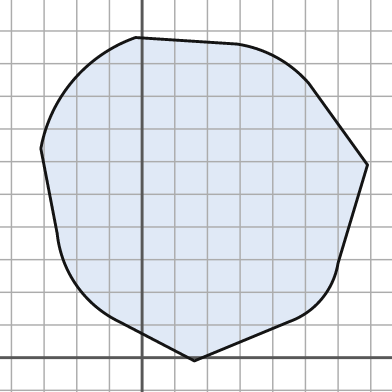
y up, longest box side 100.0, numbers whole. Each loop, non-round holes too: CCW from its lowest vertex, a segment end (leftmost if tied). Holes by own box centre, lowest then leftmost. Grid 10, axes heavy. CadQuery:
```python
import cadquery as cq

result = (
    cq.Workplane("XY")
    .moveTo(16.0, -1.0)
    .lineTo(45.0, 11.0)
    .threePointArc((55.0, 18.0), (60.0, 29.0))
    .lineTo(69.0, 59.0)
    .lineTo(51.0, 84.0)
    .threePointArc((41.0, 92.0), (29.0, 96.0))
    .lineTo(-2.0, 98.0)
    .threePointArc((-21.0, 85.0), (-31.0, 64.0))
    .lineTo(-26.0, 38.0)
    .threePointArc((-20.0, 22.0), (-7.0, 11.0))
    .close()
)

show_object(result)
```